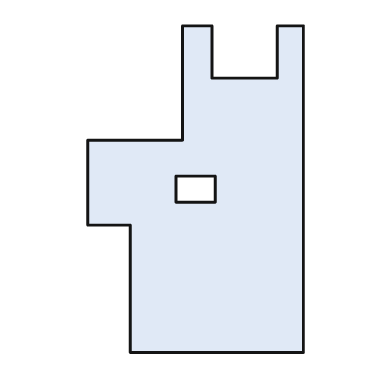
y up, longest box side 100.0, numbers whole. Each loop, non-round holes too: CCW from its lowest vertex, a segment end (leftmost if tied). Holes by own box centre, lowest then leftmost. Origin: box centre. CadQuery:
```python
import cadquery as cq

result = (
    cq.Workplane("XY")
    .moveTo(-20.0, -50.0)
    .lineTo(33.0, -50.0)
    .lineTo(33.0, 50.0)
    .lineTo(25.0, 50.0)
    .lineTo(25.0, 34.0)
    .lineTo(5.0, 34.0)
    .lineTo(5.0, 50.0)
    .lineTo(-4.0, 50.0)
    .lineTo(-4.0, 15.0)
    .lineTo(-33.0, 15.0)
    .lineTo(-33.0, -11.0)
    .lineTo(-20.0, -11.0)
    .close()
    .moveTo(-6.0, -4.0)
    .lineTo(6.0, -4.0)
    .lineTo(6.0, 4.0)
    .lineTo(-6.0, 4.0)
    .close()
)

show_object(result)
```